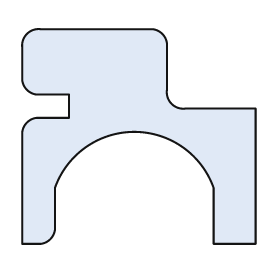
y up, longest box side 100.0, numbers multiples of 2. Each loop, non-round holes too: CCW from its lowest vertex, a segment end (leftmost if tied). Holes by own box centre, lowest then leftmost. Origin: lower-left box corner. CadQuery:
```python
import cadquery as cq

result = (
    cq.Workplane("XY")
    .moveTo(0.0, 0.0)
    .lineTo(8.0, 0.0)
    .threePointArc((12.0, 2.0), (14.0, 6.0))
    .lineTo(14.0, 24.0)
    .threePointArc((48.0, 48.0), (82.0, 24.0))
    .lineTo(82.0, 0.0)
    .lineTo(100.0, 0.0)
    .lineTo(100.0, 58.0)
    .lineTo(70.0, 58.0)
    .threePointArc((64.0, 60.0), (62.0, 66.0))
    .lineTo(62.0, 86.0)
    .threePointArc((60.0, 90.0), (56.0, 92.0))
    .lineTo(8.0, 92.0)
    .threePointArc((2.0, 90.0), (0.0, 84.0))
    .lineTo(0.0, 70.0)
    .threePointArc((2.0, 66.0), (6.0, 64.0))
    .lineTo(20.0, 64.0)
    .lineTo(20.0, 54.0)
    .lineTo(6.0, 54.0)
    .threePointArc((2.0, 52.0), (0.0, 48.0))
    .close()
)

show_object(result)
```